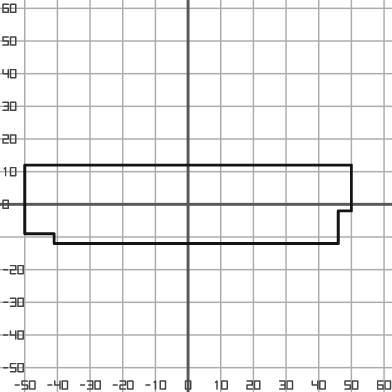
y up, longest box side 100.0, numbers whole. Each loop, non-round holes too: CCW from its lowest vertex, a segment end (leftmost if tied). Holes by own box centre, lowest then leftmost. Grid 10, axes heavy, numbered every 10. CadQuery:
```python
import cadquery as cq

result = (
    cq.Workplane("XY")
    .moveTo(-41.0, -12.0)
    .lineTo(46.0, -12.0)
    .lineTo(46.0, -2.0)
    .lineTo(50.0, -2.0)
    .lineTo(50.0, 12.0)
    .lineTo(-50.0, 12.0)
    .lineTo(-50.0, -9.0)
    .lineTo(-41.0, -9.0)
    .close()
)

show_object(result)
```